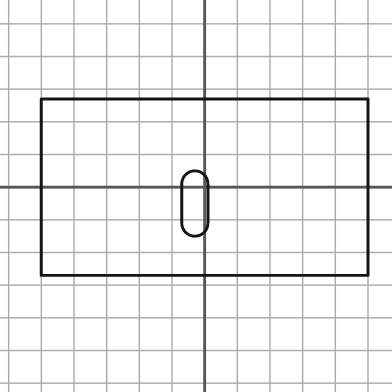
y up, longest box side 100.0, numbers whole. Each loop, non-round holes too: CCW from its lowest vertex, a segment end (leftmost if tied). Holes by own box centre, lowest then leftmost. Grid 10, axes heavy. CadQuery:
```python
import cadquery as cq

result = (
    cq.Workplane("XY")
    .moveTo(-50.0, -27.0)
    .lineTo(50.0, -27.0)
    .lineTo(50.0, 27.0)
    .lineTo(-50.0, 27.0)
    .close()
    .moveTo(-7.0, -11.0)
    .threePointArc((-3.0, -15.0), (1.0, -11.0))
    .lineTo(1.0, 1.0)
    .threePointArc((-3.0, 5.0), (-7.0, 1.0))
    .close()
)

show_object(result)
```